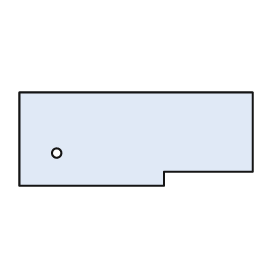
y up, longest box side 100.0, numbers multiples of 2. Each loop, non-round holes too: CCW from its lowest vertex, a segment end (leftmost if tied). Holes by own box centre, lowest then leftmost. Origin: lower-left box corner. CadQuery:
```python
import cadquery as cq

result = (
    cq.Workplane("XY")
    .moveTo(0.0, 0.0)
    .lineTo(62.0, 0.0)
    .lineTo(62.0, 6.0)
    .lineTo(100.0, 6.0)
    .lineTo(100.0, 40.0)
    .lineTo(0.0, 40.0)
    .close()
    .moveTo(16.0, 14.0)
    .circle(2.0)
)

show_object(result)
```